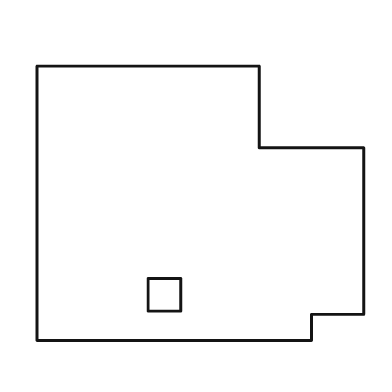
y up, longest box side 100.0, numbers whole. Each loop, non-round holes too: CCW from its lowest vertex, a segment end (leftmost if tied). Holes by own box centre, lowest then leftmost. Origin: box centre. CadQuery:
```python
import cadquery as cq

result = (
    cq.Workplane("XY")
    .moveTo(-50.0, -42.0)
    .lineTo(34.0, -42.0)
    .lineTo(34.0, -34.0)
    .lineTo(50.0, -34.0)
    .lineTo(50.0, 17.0)
    .lineTo(18.0, 17.0)
    .lineTo(18.0, 42.0)
    .lineTo(-50.0, 42.0)
    .close()
    .moveTo(-16.0, -33.0)
    .lineTo(-6.0, -33.0)
    .lineTo(-6.0, -23.0)
    .lineTo(-16.0, -23.0)
    .close()
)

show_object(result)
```